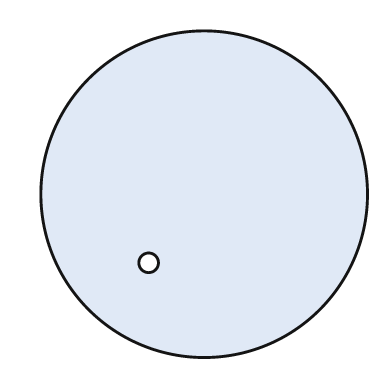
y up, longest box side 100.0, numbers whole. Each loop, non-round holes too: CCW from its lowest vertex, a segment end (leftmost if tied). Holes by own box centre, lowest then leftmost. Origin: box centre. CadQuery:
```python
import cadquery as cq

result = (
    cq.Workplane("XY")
    .moveTo(0.0, 0.0)
    .circle(50.0)
    .moveTo(-17.0, -21.0)
    .circle(3.0)
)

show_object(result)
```